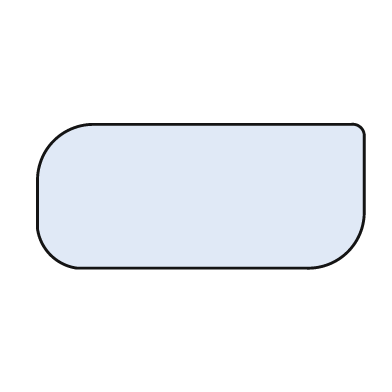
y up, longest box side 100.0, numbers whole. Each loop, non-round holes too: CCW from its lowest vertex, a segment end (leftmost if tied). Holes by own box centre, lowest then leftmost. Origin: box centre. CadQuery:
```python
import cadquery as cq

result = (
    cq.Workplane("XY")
    .moveTo(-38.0, -22.0)
    .lineTo(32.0, -22.0)
    .threePointArc((45.0, -17.0), (50.0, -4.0))
    .lineTo(50.0, 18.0)
    .threePointArc((49.0, 21.0), (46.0, 22.0))
    .lineTo(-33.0, 22.0)
    .threePointArc((-45.0, 17.0), (-50.0, 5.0))
    .lineTo(-50.0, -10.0)
    .threePointArc((-46.0, -18.0), (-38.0, -22.0))
    .close()
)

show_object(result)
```